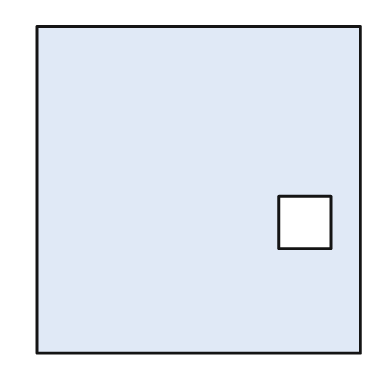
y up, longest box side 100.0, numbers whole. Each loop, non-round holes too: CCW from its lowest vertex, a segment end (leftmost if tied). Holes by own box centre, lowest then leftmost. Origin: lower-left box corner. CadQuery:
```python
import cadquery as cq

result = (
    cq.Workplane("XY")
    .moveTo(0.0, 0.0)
    .lineTo(99.0, 0.0)
    .lineTo(99.0, 100.0)
    .lineTo(0.0, 100.0)
    .close()
    .moveTo(74.0, 32.0)
    .lineTo(90.0, 32.0)
    .lineTo(90.0, 48.0)
    .lineTo(74.0, 48.0)
    .close()
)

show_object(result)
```